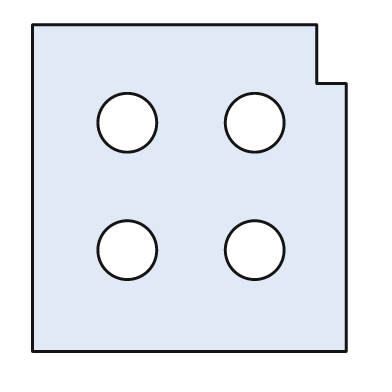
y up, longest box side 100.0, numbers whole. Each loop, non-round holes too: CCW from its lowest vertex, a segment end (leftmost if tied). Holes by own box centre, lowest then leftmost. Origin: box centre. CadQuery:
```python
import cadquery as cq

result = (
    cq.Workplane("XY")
    .moveTo(-48.0, -50.0)
    .lineTo(48.0, -50.0)
    .lineTo(48.0, 32.0)
    .lineTo(39.0, 32.0)
    .lineTo(39.0, 50.0)
    .lineTo(-48.0, 50.0)
    .close()
    .moveTo(-19.0, -19.0)
    .circle(9.0)
    .moveTo(20.0, -19.0)
    .circle(9.0)
    .moveTo(-19.0, 20.0)
    .circle(9.0)
    .moveTo(20.0, 20.0)
    .circle(9.0)
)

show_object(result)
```